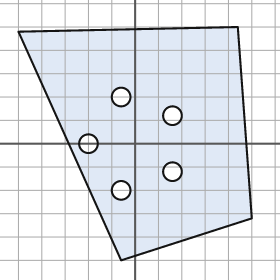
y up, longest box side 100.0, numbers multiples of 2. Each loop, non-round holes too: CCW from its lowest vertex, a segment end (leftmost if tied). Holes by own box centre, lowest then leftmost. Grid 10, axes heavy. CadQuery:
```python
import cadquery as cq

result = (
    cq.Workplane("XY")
    .moveTo(-6.0, -50.0)
    .lineTo(50.0, -32.0)
    .lineTo(44.0, 50.0)
    .lineTo(-50.0, 48.0)
    .close()
    .moveTo(-6.0, -20.0)
    .circle(4.0)
    .moveTo(16.0, -12.0)
    .circle(4.0)
    .moveTo(-20.0, 0.0)
    .circle(4.0)
    .moveTo(16.0, 12.0)
    .circle(4.0)
    .moveTo(-6.0, 20.0)
    .circle(4.0)
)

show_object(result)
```